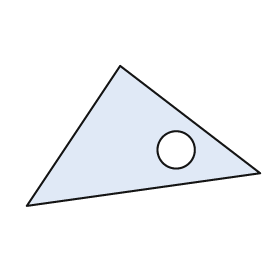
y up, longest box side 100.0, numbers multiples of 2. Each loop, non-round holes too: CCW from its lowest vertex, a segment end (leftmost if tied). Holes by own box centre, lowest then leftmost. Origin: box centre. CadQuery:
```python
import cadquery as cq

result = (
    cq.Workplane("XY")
    .moveTo(-50.0, -30.0)
    .lineTo(50.0, -16.0)
    .lineTo(-10.0, 30.0)
    .close()
    .moveTo(14.0, -6.0)
    .circle(8.0)
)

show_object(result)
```